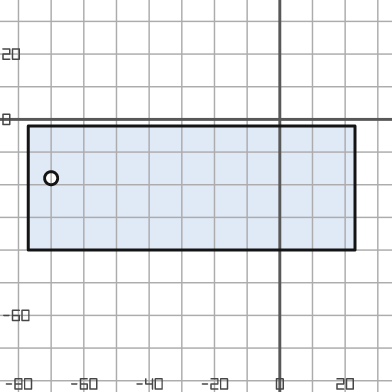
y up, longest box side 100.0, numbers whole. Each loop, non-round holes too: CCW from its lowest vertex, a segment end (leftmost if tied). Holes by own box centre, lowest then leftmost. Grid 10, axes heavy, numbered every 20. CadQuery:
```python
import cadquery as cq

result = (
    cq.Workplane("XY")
    .moveTo(-77.0, -40.0)
    .lineTo(23.0, -40.0)
    .lineTo(23.0, -2.0)
    .lineTo(-77.0, -2.0)
    .close()
    .moveTo(-70.0, -18.0)
    .circle(2.0)
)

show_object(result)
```